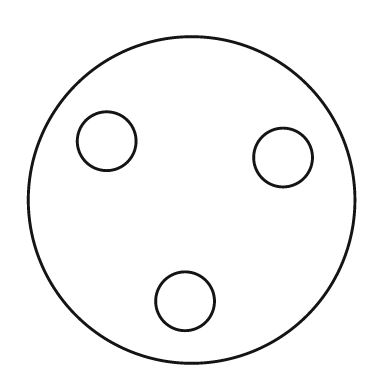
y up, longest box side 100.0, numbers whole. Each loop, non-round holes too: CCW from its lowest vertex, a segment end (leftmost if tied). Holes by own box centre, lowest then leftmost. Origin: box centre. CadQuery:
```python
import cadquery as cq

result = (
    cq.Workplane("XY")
    .moveTo(0.0, 0.0)
    .circle(50.0)
    .moveTo(-2.0, -31.0)
    .circle(9.0)
    .moveTo(28.0, 13.0)
    .circle(9.0)
    .moveTo(-26.0, 18.0)
    .circle(9.0)
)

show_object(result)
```